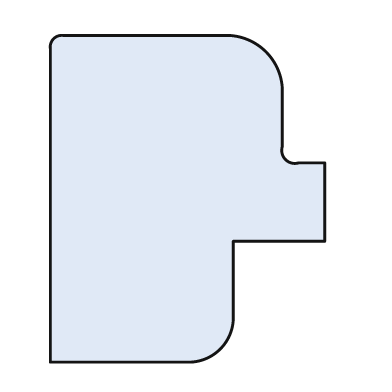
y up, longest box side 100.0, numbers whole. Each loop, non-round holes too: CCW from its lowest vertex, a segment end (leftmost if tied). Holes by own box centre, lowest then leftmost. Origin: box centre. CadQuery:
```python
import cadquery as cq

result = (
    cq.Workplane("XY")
    .moveTo(-42.0, -50.0)
    .lineTo(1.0, -50.0)
    .threePointArc((10.0, -46.0), (14.0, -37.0))
    .lineTo(14.0, -13.0)
    .lineTo(42.0, -13.0)
    .lineTo(42.0, 11.0)
    .lineTo(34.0, 11.0)
    .threePointArc((30.0, 12.0), (29.0, 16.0))
    .lineTo(29.0, 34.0)
    .threePointArc((24.0, 45.0), (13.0, 50.0))
    .lineTo(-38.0, 50.0)
    .threePointArc((-41.0, 49.0), (-42.0, 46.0))
    .close()
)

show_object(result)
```